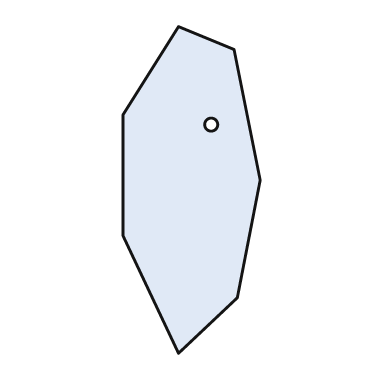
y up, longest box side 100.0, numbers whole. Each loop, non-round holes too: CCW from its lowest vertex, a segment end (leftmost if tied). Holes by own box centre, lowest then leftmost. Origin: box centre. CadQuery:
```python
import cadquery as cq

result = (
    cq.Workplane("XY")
    .moveTo(-4.0, -50.0)
    .lineTo(14.0, -33.0)
    .lineTo(21.0, 3.0)
    .lineTo(13.0, 43.0)
    .lineTo(-4.0, 50.0)
    .lineTo(-21.0, 23.0)
    .lineTo(-21.0, -14.0)
    .close()
    .moveTo(6.0, 20.0)
    .circle(2.0)
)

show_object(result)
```